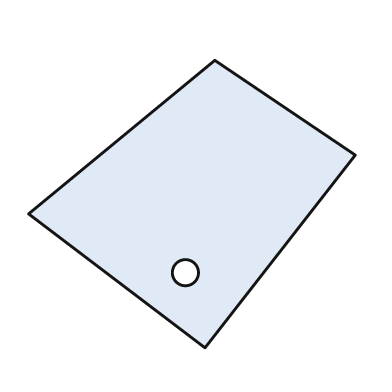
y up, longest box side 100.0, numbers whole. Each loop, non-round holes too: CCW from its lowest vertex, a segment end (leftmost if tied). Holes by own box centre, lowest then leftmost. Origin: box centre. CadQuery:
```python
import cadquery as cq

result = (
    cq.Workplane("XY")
    .moveTo(4.0, -44.0)
    .lineTo(50.0, 15.0)
    .lineTo(7.0, 44.0)
    .lineTo(-50.0, -3.0)
    .close()
    .moveTo(-2.0, -21.0)
    .circle(4.0)
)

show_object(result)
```